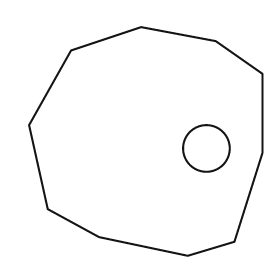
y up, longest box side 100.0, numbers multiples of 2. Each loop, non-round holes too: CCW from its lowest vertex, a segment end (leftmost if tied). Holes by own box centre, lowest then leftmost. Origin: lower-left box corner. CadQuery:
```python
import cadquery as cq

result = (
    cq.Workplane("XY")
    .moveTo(68.0, 0.0)
    .lineTo(88.0, 6.0)
    .lineTo(100.0, 44.0)
    .lineTo(100.0, 78.0)
    .lineTo(80.0, 92.0)
    .lineTo(48.0, 98.0)
    .lineTo(18.0, 88.0)
    .lineTo(0.0, 56.0)
    .lineTo(8.0, 20.0)
    .lineTo(30.0, 8.0)
    .close()
    .moveTo(76.0, 46.0)
    .circle(10.0)
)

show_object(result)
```